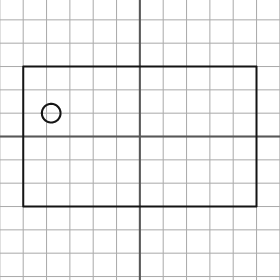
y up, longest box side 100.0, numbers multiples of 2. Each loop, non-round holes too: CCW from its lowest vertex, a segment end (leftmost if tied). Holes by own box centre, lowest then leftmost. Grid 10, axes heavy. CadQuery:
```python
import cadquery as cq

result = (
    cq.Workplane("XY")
    .moveTo(-50.0, -30.0)
    .lineTo(50.0, -30.0)
    .lineTo(50.0, 30.0)
    .lineTo(-50.0, 30.0)
    .close()
    .moveTo(-38.0, 10.0)
    .circle(4.0)
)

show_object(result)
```